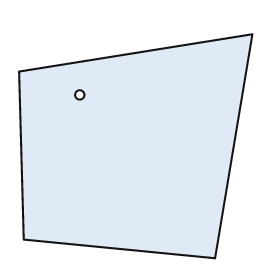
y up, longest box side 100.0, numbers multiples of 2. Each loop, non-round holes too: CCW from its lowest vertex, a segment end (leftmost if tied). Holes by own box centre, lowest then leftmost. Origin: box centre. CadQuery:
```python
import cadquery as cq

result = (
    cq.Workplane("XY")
    .moveTo(34.0, -48.0)
    .lineTo(50.0, 48.0)
    .lineTo(-50.0, 32.0)
    .lineTo(-48.0, -40.0)
    .close()
    .moveTo(-24.0, 22.0)
    .circle(2.0)
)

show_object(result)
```